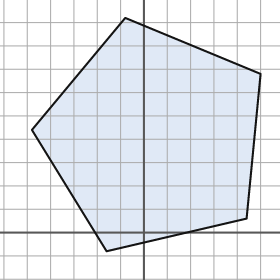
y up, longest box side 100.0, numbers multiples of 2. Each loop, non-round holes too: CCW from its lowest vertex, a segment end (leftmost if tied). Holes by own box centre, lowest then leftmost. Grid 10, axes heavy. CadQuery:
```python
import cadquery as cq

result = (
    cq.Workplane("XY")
    .moveTo(-16.0, -8.0)
    .lineTo(44.0, 6.0)
    .lineTo(50.0, 68.0)
    .lineTo(-8.0, 92.0)
    .lineTo(-48.0, 44.0)
    .close()
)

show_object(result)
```